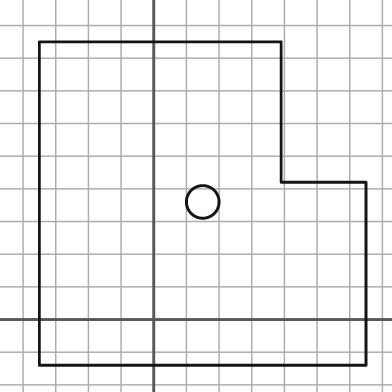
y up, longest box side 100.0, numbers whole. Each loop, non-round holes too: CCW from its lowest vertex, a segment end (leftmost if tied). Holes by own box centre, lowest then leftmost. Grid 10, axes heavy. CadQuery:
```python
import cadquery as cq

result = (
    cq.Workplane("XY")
    .moveTo(-35.0, -14.0)
    .lineTo(65.0, -14.0)
    .lineTo(65.0, 42.0)
    .lineTo(39.0, 42.0)
    .lineTo(39.0, 85.0)
    .lineTo(-35.0, 85.0)
    .close()
    .moveTo(15.0, 36.0)
    .circle(5.0)
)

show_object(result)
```